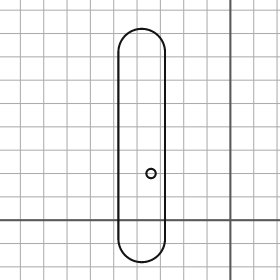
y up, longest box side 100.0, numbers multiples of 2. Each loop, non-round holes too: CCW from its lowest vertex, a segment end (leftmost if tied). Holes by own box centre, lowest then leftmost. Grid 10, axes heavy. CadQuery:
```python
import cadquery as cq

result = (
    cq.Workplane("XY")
    .moveTo(-48.0, -8.0)
    .threePointArc((-38.0, -18.0), (-28.0, -8.0))
    .lineTo(-28.0, 72.0)
    .threePointArc((-38.0, 82.0), (-48.0, 72.0))
    .close()
    .moveTo(-34.0, 20.0)
    .circle(2.0)
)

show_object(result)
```